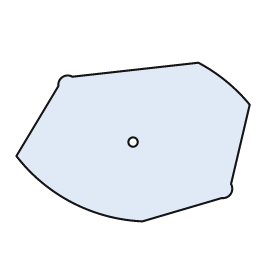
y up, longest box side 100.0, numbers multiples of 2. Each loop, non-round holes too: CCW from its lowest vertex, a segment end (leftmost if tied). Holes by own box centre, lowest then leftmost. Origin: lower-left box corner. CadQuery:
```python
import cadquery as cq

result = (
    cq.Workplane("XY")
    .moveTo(54.0, 0.0)
    .lineTo(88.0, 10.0)
    .threePointArc((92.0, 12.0), (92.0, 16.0))
    .lineTo(100.0, 50.0)
    .threePointArc((90.0, 60.0), (78.0, 68.0))
    .lineTo(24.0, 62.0)
    .threePointArc((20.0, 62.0), (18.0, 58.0))
    .lineTo(0.0, 28.0)
    .threePointArc((24.0, 8.0), (54.0, 0.0))
    .close()
    .moveTo(50.0, 34.0)
    .circle(2.0)
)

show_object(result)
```